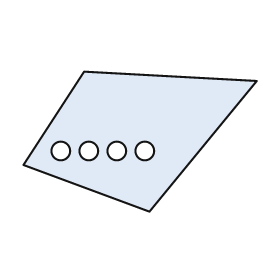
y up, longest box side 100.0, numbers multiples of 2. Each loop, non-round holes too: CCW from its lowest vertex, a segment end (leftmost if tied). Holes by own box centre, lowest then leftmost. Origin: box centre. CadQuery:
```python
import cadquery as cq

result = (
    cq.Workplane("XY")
    .moveTo(4.0, -30.0)
    .lineTo(50.0, 26.0)
    .lineTo(-24.0, 30.0)
    .lineTo(-50.0, -10.0)
    .close()
    .moveTo(-34.0, -4.0)
    .circle(4.0)
    .moveTo(-22.0, -4.0)
    .circle(4.0)
    .moveTo(-10.0, -4.0)
    .circle(4.0)
    .moveTo(2.0, -4.0)
    .circle(4.0)
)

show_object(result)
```